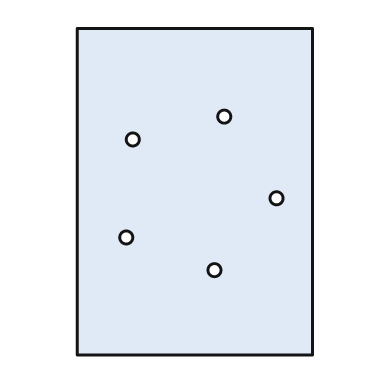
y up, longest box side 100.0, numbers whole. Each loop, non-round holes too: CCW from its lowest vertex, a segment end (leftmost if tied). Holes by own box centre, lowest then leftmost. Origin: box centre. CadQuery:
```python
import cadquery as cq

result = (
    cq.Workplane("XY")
    .moveTo(-36.0, -50.0)
    .lineTo(36.0, -50.0)
    .lineTo(36.0, 50.0)
    .lineTo(-36.0, 50.0)
    .close()
    .moveTo(6.0, -24.0)
    .circle(2.0)
    .moveTo(-21.0, -14.0)
    .circle(2.0)
    .moveTo(25.0, -2.0)
    .circle(2.0)
    .moveTo(-19.0, 16.0)
    .circle(2.0)
    .moveTo(9.0, 23.0)
    .circle(2.0)
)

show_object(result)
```